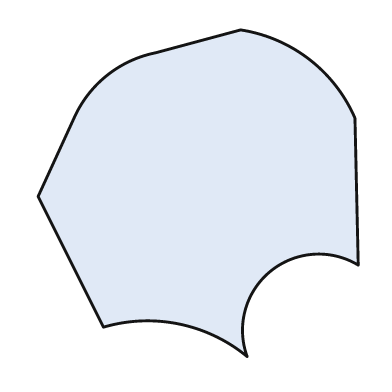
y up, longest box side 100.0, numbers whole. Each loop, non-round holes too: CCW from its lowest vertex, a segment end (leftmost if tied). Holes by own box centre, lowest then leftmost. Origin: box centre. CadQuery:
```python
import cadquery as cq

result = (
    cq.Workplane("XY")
    .moveTo(15.0, -50.0)
    .threePointArc((22.0, -24.0), (49.0, -22.0))
    .lineTo(48.0, 23.0)
    .threePointArc((34.0, 41.0), (13.0, 50.0))
    .lineTo(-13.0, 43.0)
    .threePointArc((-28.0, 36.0), (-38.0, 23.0))
    .lineTo(-49.0, -1.0)
    .lineTo(-29.0, -41.0)
    .threePointArc((-6.0, -40.0), (15.0, -50.0))
    .close()
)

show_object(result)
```